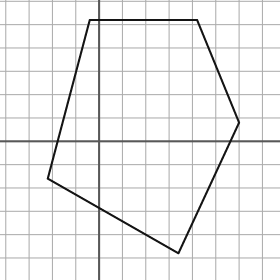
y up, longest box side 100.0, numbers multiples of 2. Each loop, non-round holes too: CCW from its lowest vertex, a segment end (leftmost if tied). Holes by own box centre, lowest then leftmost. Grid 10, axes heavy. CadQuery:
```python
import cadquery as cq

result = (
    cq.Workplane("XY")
    .moveTo(34.0, -48.0)
    .lineTo(60.0, 8.0)
    .lineTo(42.0, 52.0)
    .lineTo(-4.0, 52.0)
    .lineTo(-22.0, -16.0)
    .close()
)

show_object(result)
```